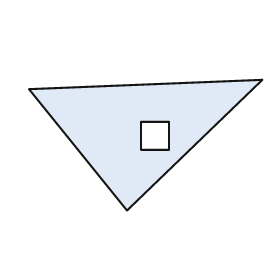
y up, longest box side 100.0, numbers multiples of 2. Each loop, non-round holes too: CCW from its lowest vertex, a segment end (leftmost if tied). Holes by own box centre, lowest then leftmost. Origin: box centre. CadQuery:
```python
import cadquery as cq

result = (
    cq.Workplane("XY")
    .moveTo(-8.0, -28.0)
    .lineTo(50.0, 28.0)
    .lineTo(-50.0, 24.0)
    .close()
    .moveTo(-2.0, -2.0)
    .lineTo(10.0, -2.0)
    .lineTo(10.0, 10.0)
    .lineTo(-2.0, 10.0)
    .close()
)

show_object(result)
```